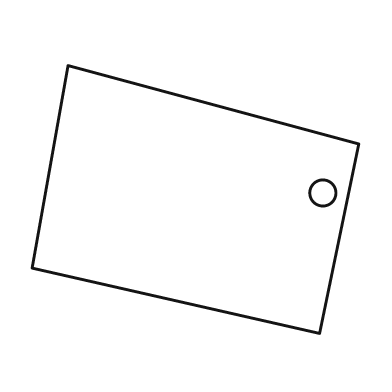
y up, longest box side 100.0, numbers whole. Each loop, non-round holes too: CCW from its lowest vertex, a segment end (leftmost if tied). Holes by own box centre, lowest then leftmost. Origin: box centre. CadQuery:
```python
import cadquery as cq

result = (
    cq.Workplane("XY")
    .moveTo(38.0, -41.0)
    .lineTo(50.0, 17.0)
    .lineTo(-39.0, 41.0)
    .lineTo(-50.0, -21.0)
    .close()
    .moveTo(39.0, 2.0)
    .circle(4.0)
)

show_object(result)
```